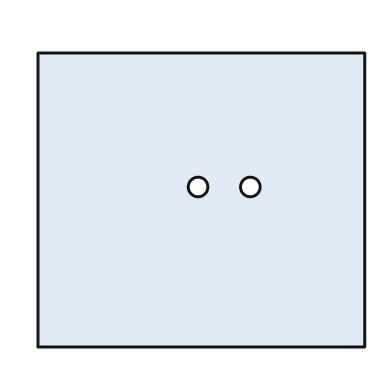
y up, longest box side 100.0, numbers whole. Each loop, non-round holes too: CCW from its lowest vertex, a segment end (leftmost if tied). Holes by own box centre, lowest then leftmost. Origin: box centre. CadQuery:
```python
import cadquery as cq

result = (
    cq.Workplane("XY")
    .moveTo(-50.0, -45.0)
    .lineTo(50.0, -45.0)
    .lineTo(50.0, 45.0)
    .lineTo(-50.0, 45.0)
    .close()
    .moveTo(-1.0, 4.0)
    .circle(3.0)
    .moveTo(15.0, 4.0)
    .circle(3.0)
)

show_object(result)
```